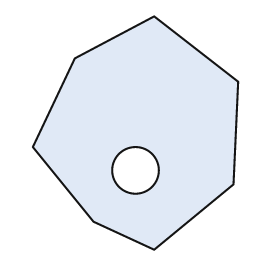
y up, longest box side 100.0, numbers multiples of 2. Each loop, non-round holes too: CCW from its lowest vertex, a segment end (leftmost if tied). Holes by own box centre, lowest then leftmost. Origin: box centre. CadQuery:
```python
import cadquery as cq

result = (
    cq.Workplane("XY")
    .moveTo(8.0, -50.0)
    .lineTo(42.0, -22.0)
    .lineTo(44.0, 22.0)
    .lineTo(8.0, 50.0)
    .lineTo(-26.0, 32.0)
    .lineTo(-44.0, -6.0)
    .lineTo(-18.0, -38.0)
    .close()
    .moveTo(0.0, -16.0)
    .circle(10.0)
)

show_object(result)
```